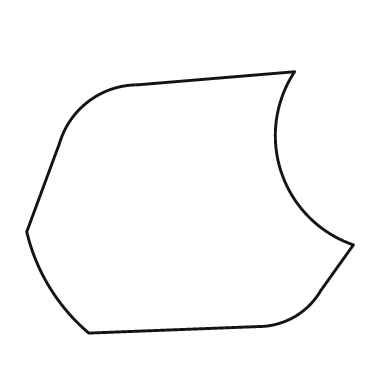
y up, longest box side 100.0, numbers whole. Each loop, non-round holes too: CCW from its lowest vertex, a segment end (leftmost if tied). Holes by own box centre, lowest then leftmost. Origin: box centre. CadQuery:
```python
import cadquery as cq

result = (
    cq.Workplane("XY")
    .moveTo(-31.0, -40.0)
    .lineTo(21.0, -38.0)
    .threePointArc((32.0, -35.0), (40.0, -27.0))
    .lineTo(50.0, -13.0)
    .threePointArc((28.0, 9.0), (32.0, 40.0))
    .lineTo(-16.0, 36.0)
    .threePointArc((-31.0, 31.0), (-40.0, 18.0))
    .lineTo(-50.0, -9.0)
    .threePointArc((-43.0, -26.0), (-31.0, -40.0))
    .close()
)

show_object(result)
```